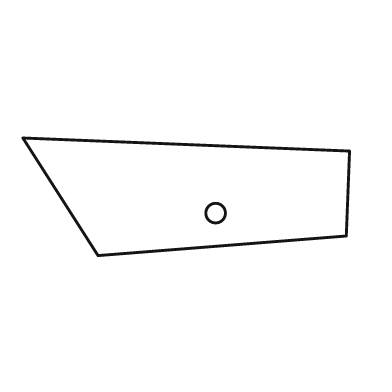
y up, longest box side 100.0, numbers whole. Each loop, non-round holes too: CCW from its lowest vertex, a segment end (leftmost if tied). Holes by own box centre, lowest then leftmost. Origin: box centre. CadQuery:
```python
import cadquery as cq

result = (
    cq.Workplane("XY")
    .moveTo(-27.0, -18.0)
    .lineTo(49.0, -12.0)
    .lineTo(50.0, 14.0)
    .lineTo(-50.0, 18.0)
    .close()
    .moveTo(9.0, -5.0)
    .circle(3.0)
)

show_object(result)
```